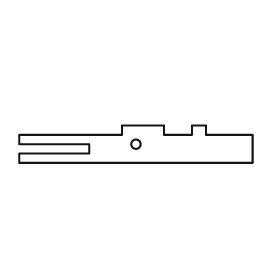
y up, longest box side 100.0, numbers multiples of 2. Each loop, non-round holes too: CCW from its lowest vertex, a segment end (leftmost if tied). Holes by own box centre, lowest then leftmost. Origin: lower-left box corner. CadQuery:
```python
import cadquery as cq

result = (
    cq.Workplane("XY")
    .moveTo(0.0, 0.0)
    .lineTo(100.0, 0.0)
    .lineTo(100.0, 12.0)
    .lineTo(80.0, 12.0)
    .lineTo(80.0, 16.0)
    .lineTo(74.0, 16.0)
    .lineTo(74.0, 12.0)
    .lineTo(62.0, 12.0)
    .lineTo(62.0, 16.0)
    .lineTo(44.0, 16.0)
    .lineTo(44.0, 12.0)
    .lineTo(0.0, 12.0)
    .lineTo(0.0, 8.0)
    .lineTo(30.0, 8.0)
    .lineTo(30.0, 4.0)
    .lineTo(0.0, 4.0)
    .close()
    .moveTo(50.0, 8.0)
    .circle(2.0)
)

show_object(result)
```